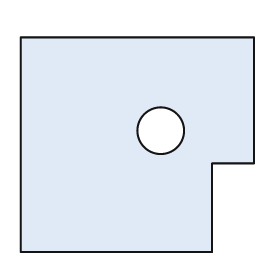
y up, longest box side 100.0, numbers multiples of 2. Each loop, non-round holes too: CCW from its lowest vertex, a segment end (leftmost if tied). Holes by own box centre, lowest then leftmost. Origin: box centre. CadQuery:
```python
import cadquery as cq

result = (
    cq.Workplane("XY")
    .moveTo(-50.0, -46.0)
    .lineTo(32.0, -46.0)
    .lineTo(32.0, -8.0)
    .lineTo(50.0, -8.0)
    .lineTo(50.0, 46.0)
    .lineTo(-50.0, 46.0)
    .close()
    .moveTo(10.0, 6.0)
    .circle(10.0)
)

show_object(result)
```